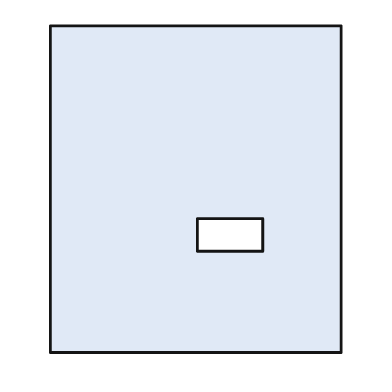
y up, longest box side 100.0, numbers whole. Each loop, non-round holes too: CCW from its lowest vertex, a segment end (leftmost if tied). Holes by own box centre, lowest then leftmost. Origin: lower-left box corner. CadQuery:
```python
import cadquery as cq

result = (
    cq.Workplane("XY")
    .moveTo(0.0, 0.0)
    .lineTo(89.0, 0.0)
    .lineTo(89.0, 100.0)
    .lineTo(0.0, 100.0)
    .close()
    .moveTo(45.0, 31.0)
    .lineTo(65.0, 31.0)
    .lineTo(65.0, 41.0)
    .lineTo(45.0, 41.0)
    .close()
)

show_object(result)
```